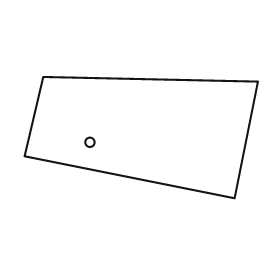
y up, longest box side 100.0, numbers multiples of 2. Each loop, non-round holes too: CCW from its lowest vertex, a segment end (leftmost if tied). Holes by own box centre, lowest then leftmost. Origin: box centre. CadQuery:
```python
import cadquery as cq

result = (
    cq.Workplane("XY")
    .moveTo(40.0, -26.0)
    .lineTo(50.0, 24.0)
    .lineTo(-42.0, 26.0)
    .lineTo(-50.0, -8.0)
    .close()
    .moveTo(-22.0, -2.0)
    .circle(2.0)
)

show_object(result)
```